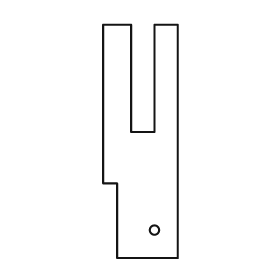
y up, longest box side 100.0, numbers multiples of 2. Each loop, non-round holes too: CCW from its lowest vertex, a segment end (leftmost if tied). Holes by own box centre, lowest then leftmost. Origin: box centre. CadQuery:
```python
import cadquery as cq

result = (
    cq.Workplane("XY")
    .moveTo(-10.0, -50.0)
    .lineTo(16.0, -50.0)
    .lineTo(16.0, 50.0)
    .lineTo(6.0, 50.0)
    .lineTo(6.0, 4.0)
    .lineTo(-4.0, 4.0)
    .lineTo(-4.0, 50.0)
    .lineTo(-16.0, 50.0)
    .lineTo(-16.0, -18.0)
    .lineTo(-10.0, -18.0)
    .close()
    .moveTo(6.0, -38.0)
    .circle(2.0)
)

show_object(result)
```